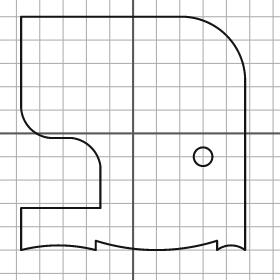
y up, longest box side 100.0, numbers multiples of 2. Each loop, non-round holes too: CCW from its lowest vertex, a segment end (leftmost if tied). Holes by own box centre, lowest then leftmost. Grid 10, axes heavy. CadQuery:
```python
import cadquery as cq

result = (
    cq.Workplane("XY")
    .moveTo(-48.0, -50.0)
    .threePointArc((-32.0, -48.0), (-16.0, -50.0))
    .lineTo(-16.0, -46.0)
    .threePointArc((10.0, -50.0), (36.0, -46.0))
    .lineTo(36.0, -50.0)
    .threePointArc((42.0, -48.0), (48.0, -50.0))
    .lineTo(48.0, 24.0)
    .threePointArc((40.0, 42.0), (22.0, 50.0))
    .lineTo(-48.0, 50.0)
    .lineTo(-48.0, 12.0)
    .threePointArc((-44.0, 2.0), (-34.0, -2.0))
    .lineTo(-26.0, -2.0)
    .threePointArc((-18.0, -6.0), (-14.0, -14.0))
    .lineTo(-14.0, -32.0)
    .lineTo(-48.0, -32.0)
    .close()
    .moveTo(30.0, -10.0)
    .circle(4.0)
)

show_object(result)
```